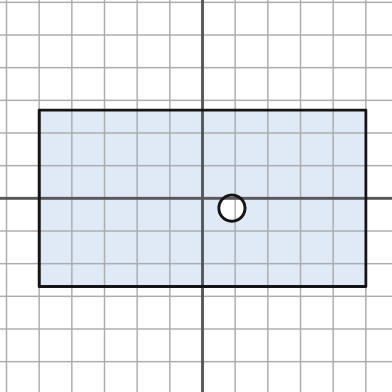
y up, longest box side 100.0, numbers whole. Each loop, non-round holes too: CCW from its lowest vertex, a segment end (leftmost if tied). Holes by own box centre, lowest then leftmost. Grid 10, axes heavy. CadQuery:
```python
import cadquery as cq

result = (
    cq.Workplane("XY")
    .moveTo(-50.0, -27.0)
    .lineTo(50.0, -27.0)
    .lineTo(50.0, 27.0)
    .lineTo(-50.0, 27.0)
    .close()
    .moveTo(9.0, -3.0)
    .circle(4.0)
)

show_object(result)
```